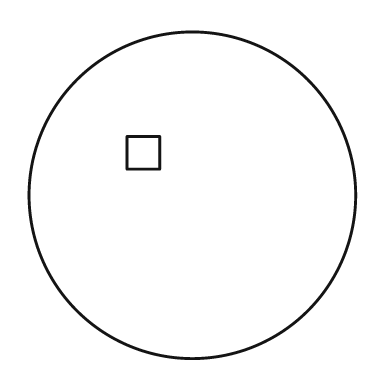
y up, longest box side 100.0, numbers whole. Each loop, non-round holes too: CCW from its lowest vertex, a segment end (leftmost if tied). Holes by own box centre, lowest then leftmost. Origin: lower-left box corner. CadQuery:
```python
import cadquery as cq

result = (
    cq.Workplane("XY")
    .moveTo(50.0, 50.0)
    .circle(50.0)
    .moveTo(30.0, 58.0)
    .lineTo(40.0, 58.0)
    .lineTo(40.0, 68.0)
    .lineTo(30.0, 68.0)
    .close()
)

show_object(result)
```